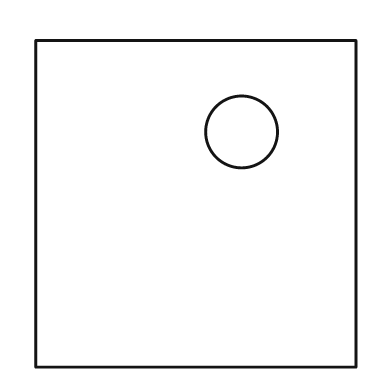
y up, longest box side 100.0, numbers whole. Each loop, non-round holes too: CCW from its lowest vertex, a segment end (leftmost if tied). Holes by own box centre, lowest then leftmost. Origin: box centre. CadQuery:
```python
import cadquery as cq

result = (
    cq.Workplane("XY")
    .moveTo(-49.0, -50.0)
    .lineTo(49.0, -50.0)
    .lineTo(49.0, 50.0)
    .lineTo(-49.0, 50.0)
    .close()
    .moveTo(14.0, 22.0)
    .circle(11.0)
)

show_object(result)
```